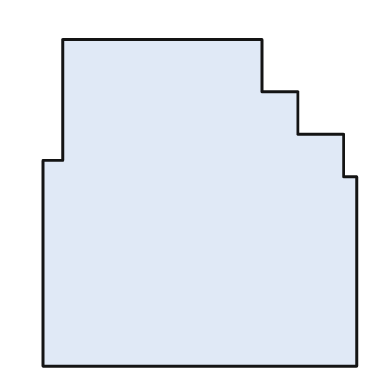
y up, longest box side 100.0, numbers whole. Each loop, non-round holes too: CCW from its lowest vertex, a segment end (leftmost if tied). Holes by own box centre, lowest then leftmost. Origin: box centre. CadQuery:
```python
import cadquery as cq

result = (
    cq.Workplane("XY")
    .moveTo(-48.0, -50.0)
    .lineTo(48.0, -50.0)
    .lineTo(48.0, 8.0)
    .lineTo(44.0, 8.0)
    .lineTo(44.0, 21.0)
    .lineTo(30.0, 21.0)
    .lineTo(30.0, 34.0)
    .lineTo(19.0, 34.0)
    .lineTo(19.0, 50.0)
    .lineTo(-42.0, 50.0)
    .lineTo(-42.0, 13.0)
    .lineTo(-48.0, 13.0)
    .close()
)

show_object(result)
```